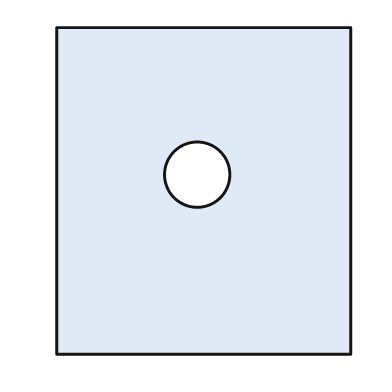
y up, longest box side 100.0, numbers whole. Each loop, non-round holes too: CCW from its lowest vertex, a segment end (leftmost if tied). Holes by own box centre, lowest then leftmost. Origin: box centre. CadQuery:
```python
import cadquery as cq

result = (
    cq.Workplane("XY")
    .moveTo(-45.0, -50.0)
    .lineTo(45.0, -50.0)
    .lineTo(45.0, 50.0)
    .lineTo(-45.0, 50.0)
    .close()
    .moveTo(-2.0, 5.0)
    .circle(10.0)
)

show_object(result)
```